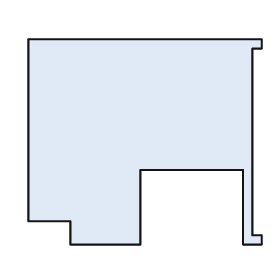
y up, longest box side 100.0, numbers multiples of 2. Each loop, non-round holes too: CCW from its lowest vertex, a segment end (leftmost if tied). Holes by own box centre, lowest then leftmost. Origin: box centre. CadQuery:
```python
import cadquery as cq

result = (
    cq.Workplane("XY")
    .moveTo(-32.0, -44.0)
    .lineTo(-2.0, -44.0)
    .lineTo(-2.0, -12.0)
    .lineTo(42.0, -12.0)
    .lineTo(42.0, -44.0)
    .lineTo(50.0, -44.0)
    .lineTo(50.0, -40.0)
    .lineTo(46.0, -40.0)
    .lineTo(46.0, 40.0)
    .lineTo(50.0, 40.0)
    .lineTo(50.0, 44.0)
    .lineTo(-50.0, 44.0)
    .lineTo(-50.0, -34.0)
    .lineTo(-32.0, -34.0)
    .close()
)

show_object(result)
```